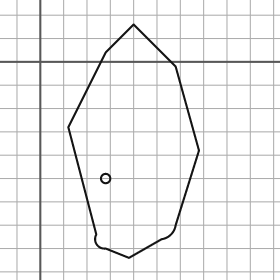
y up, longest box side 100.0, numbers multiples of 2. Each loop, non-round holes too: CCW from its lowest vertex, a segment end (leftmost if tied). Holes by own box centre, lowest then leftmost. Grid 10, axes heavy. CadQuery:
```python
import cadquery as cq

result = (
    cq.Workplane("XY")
    .moveTo(38.0, -84.0)
    .lineTo(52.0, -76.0)
    .threePointArc((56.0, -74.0), (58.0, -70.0))
    .lineTo(68.0, -38.0)
    .lineTo(58.0, -2.0)
    .lineTo(40.0, 16.0)
    .lineTo(28.0, 4.0)
    .lineTo(12.0, -28.0)
    .lineTo(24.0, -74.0)
    .threePointArc((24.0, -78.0), (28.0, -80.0))
    .close()
    .moveTo(28.0, -50.0)
    .circle(2.0)
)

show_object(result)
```